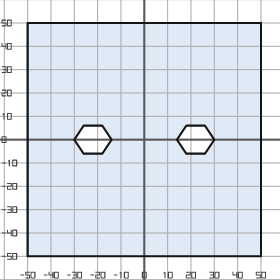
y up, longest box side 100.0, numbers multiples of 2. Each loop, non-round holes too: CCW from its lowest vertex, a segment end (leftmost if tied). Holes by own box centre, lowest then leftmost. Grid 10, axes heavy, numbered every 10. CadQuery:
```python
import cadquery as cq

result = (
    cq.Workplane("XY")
    .moveTo(-50.0, -50.0)
    .lineTo(50.0, -50.0)
    .lineTo(50.0, 50.0)
    .lineTo(-50.0, 50.0)
    .close()
    .moveTo(-26.0, -6.0)
    .lineTo(-18.0, -6.0)
    .lineTo(-14.0, 0.0)
    .lineTo(-18.0, 6.0)
    .lineTo(-26.0, 6.0)
    .lineTo(-30.0, 0.0)
    .close()
    .moveTo(18.0, -6.0)
    .lineTo(26.0, -6.0)
    .lineTo(30.0, 0.0)
    .lineTo(26.0, 6.0)
    .lineTo(18.0, 6.0)
    .lineTo(14.0, 0.0)
    .close()
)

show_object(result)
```